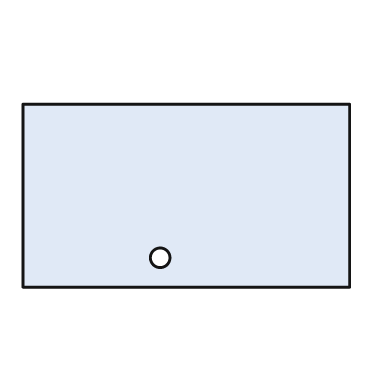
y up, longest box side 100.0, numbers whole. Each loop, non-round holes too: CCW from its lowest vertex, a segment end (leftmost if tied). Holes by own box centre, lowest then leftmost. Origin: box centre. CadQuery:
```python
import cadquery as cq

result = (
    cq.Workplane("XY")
    .moveTo(-50.0, -28.0)
    .lineTo(50.0, -28.0)
    .lineTo(50.0, 28.0)
    .lineTo(-50.0, 28.0)
    .close()
    .moveTo(-8.0, -19.0)
    .circle(3.0)
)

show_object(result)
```